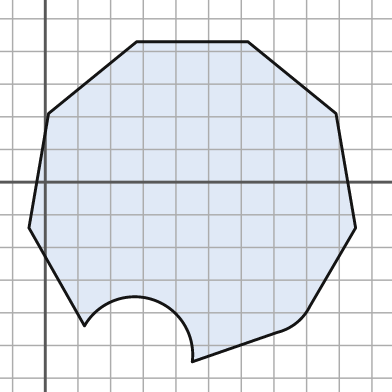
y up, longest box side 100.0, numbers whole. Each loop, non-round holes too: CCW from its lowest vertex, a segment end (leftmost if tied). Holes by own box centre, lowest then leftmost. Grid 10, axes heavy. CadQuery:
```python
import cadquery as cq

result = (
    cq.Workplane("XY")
    .moveTo(45.0, -55.0)
    .lineTo(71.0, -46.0)
    .threePointArc((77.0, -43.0), (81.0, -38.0))
    .lineTo(95.0, -14.0)
    .lineTo(89.0, 21.0)
    .lineTo(62.0, 43.0)
    .lineTo(28.0, 43.0)
    .lineTo(1.0, 21.0)
    .lineTo(-5.0, -14.0)
    .lineTo(12.0, -44.0)
    .threePointArc((33.0, -36.0), (45.0, -55.0))
    .close()
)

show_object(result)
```